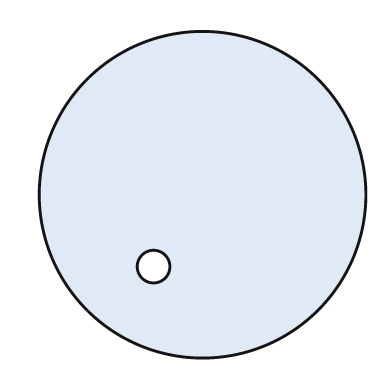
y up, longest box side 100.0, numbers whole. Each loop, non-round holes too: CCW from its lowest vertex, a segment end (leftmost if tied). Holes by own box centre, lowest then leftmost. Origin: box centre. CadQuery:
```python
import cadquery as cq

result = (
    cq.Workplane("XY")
    .moveTo(0.0, 0.0)
    .circle(50.0)
    .moveTo(-15.0, -22.0)
    .circle(5.0)
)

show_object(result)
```